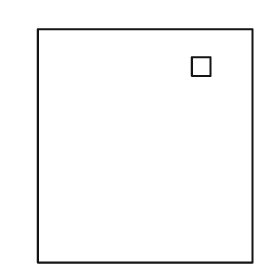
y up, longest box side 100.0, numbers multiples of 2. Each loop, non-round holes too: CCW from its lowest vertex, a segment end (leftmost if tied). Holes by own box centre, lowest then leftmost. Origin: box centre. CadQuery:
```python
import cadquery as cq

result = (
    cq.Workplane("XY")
    .moveTo(-46.0, -50.0)
    .lineTo(46.0, -50.0)
    .lineTo(46.0, 50.0)
    .lineTo(-46.0, 50.0)
    .close()
    .moveTo(20.0, 30.0)
    .lineTo(28.0, 30.0)
    .lineTo(28.0, 38.0)
    .lineTo(20.0, 38.0)
    .close()
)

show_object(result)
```